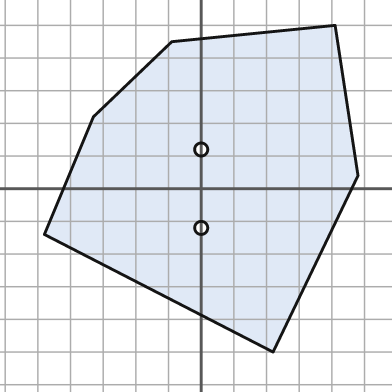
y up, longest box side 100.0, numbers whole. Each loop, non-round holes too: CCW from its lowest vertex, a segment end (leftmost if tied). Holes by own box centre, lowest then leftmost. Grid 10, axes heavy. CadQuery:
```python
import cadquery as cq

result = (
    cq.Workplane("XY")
    .moveTo(22.0, -50.0)
    .lineTo(48.0, 4.0)
    .lineTo(41.0, 50.0)
    .lineTo(-9.0, 45.0)
    .lineTo(-33.0, 22.0)
    .lineTo(-48.0, -14.0)
    .close()
    .moveTo(0.0, -12.0)
    .circle(2.0)
    .moveTo(0.0, 12.0)
    .circle(2.0)
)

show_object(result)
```